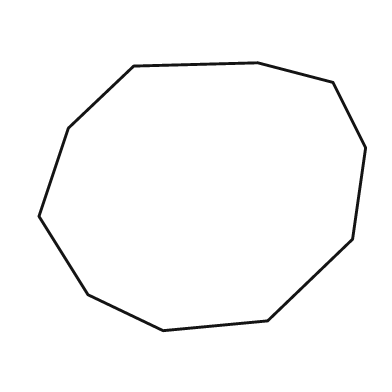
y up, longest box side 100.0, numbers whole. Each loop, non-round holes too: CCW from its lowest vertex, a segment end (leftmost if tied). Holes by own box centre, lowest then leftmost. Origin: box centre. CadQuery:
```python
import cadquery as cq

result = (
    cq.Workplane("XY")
    .moveTo(-12.0, -41.0)
    .lineTo(20.0, -38.0)
    .lineTo(46.0, -13.0)
    .lineTo(50.0, 15.0)
    .lineTo(40.0, 35.0)
    .lineTo(17.0, 41.0)
    .lineTo(-21.0, 40.0)
    .lineTo(-41.0, 21.0)
    .lineTo(-50.0, -6.0)
    .lineTo(-35.0, -30.0)
    .close()
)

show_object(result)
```